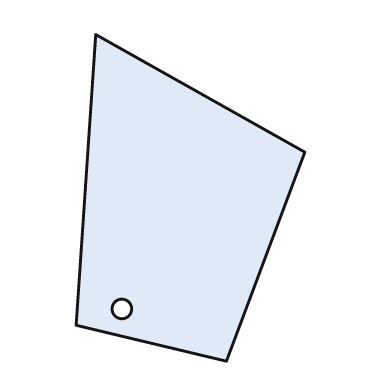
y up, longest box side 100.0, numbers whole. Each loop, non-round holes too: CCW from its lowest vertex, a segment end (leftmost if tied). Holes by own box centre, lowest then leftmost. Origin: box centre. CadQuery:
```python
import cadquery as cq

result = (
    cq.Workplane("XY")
    .moveTo(11.0, -50.0)
    .lineTo(35.0, 14.0)
    .lineTo(-29.0, 50.0)
    .lineTo(-35.0, -39.0)
    .close()
    .moveTo(-21.0, -34.0)
    .circle(3.0)
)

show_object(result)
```